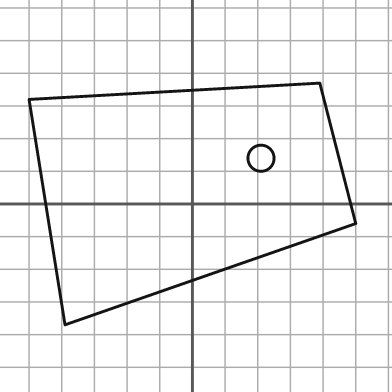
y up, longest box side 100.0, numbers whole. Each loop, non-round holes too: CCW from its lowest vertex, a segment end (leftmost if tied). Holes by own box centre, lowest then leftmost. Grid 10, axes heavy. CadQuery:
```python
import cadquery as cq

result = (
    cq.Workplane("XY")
    .moveTo(-39.0, -37.0)
    .lineTo(50.0, -6.0)
    .lineTo(39.0, 37.0)
    .lineTo(-50.0, 32.0)
    .close()
    .moveTo(21.0, 14.0)
    .circle(4.0)
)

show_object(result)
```